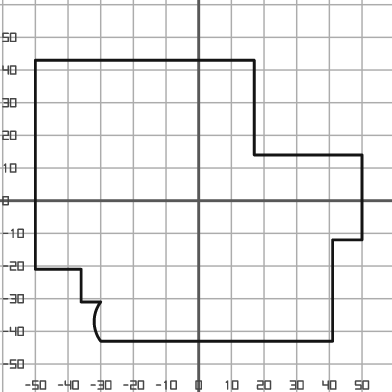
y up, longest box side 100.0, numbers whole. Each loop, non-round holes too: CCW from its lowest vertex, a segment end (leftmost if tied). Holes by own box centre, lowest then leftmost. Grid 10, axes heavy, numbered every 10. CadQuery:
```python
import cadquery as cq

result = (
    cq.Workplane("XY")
    .moveTo(-30.0, -43.0)
    .lineTo(41.0, -43.0)
    .lineTo(41.0, -12.0)
    .lineTo(50.0, -12.0)
    .lineTo(50.0, 14.0)
    .lineTo(17.0, 14.0)
    .lineTo(17.0, 43.0)
    .lineTo(-50.0, 43.0)
    .lineTo(-50.0, -21.0)
    .lineTo(-36.0, -21.0)
    .lineTo(-36.0, -31.0)
    .lineTo(-30.0, -31.0)
    .threePointArc((-32.0, -37.0), (-30.0, -43.0))
    .close()
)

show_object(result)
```